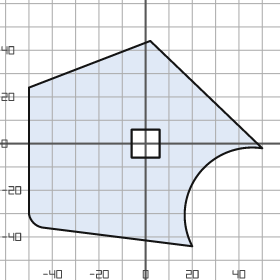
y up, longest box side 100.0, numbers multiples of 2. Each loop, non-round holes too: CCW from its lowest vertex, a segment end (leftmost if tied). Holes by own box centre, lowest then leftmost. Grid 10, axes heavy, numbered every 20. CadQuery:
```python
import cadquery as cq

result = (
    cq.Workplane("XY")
    .moveTo(20.0, -44.0)
    .threePointArc((22.0, -14.0), (50.0, -2.0))
    .lineTo(2.0, 44.0)
    .lineTo(-50.0, 24.0)
    .lineTo(-50.0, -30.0)
    .threePointArc((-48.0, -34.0), (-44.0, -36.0))
    .close()
    .moveTo(-6.0, -6.0)
    .lineTo(6.0, -6.0)
    .lineTo(6.0, 6.0)
    .lineTo(-6.0, 6.0)
    .close()
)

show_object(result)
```